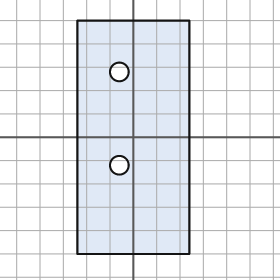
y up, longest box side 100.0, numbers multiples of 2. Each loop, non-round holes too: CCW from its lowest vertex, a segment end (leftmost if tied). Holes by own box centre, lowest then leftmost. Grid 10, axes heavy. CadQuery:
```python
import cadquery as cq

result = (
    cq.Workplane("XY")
    .moveTo(-24.0, -50.0)
    .lineTo(24.0, -50.0)
    .lineTo(24.0, 50.0)
    .lineTo(-24.0, 50.0)
    .close()
    .moveTo(-6.0, -12.0)
    .circle(4.0)
    .moveTo(-6.0, 28.0)
    .circle(4.0)
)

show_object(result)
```